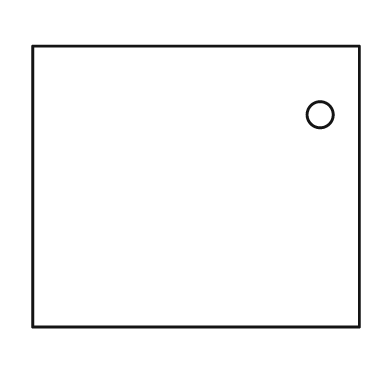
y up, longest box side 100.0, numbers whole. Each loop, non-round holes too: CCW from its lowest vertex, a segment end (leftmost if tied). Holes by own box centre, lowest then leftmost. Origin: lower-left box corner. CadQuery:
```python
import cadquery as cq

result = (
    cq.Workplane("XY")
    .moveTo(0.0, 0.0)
    .lineTo(100.0, 0.0)
    .lineTo(100.0, 86.0)
    .lineTo(0.0, 86.0)
    .close()
    .moveTo(88.0, 65.0)
    .circle(4.0)
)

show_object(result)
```